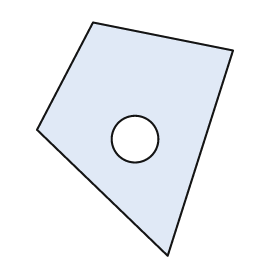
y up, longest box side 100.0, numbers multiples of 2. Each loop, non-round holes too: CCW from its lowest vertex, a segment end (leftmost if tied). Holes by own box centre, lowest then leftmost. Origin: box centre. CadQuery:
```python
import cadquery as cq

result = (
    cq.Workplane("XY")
    .moveTo(14.0, -50.0)
    .lineTo(42.0, 38.0)
    .lineTo(-18.0, 50.0)
    .lineTo(-42.0, 4.0)
    .close()
    .moveTo(0.0, 0.0)
    .circle(10.0)
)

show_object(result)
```